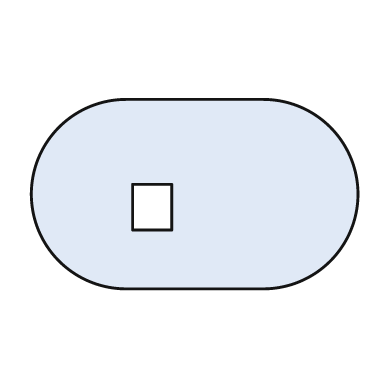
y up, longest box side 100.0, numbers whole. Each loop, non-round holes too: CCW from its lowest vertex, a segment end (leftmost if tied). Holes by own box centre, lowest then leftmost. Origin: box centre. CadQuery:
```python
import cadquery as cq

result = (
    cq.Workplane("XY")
    .moveTo(-21.0, -29.0)
    .lineTo(21.0, -29.0)
    .threePointArc((50.0, 0.0), (21.0, 29.0))
    .lineTo(-21.0, 29.0)
    .threePointArc((-50.0, 0.0), (-21.0, -29.0))
    .close()
    .moveTo(-19.0, -11.0)
    .lineTo(-7.0, -11.0)
    .lineTo(-7.0, 3.0)
    .lineTo(-19.0, 3.0)
    .close()
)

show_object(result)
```